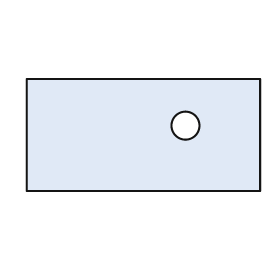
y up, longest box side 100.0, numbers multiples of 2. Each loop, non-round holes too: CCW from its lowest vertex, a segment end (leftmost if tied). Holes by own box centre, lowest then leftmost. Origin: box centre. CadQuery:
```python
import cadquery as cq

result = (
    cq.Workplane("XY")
    .moveTo(-50.0, -24.0)
    .lineTo(50.0, -24.0)
    .lineTo(50.0, 24.0)
    .lineTo(-50.0, 24.0)
    .close()
    .moveTo(18.0, 4.0)
    .circle(6.0)
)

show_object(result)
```